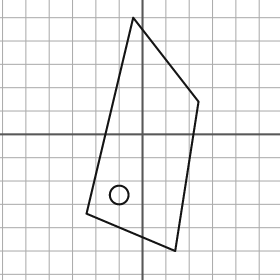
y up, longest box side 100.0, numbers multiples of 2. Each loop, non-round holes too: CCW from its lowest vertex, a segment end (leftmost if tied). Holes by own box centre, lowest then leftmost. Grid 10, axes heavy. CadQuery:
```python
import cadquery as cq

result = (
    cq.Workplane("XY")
    .moveTo(14.0, -50.0)
    .lineTo(24.0, 14.0)
    .lineTo(-4.0, 50.0)
    .lineTo(-24.0, -34.0)
    .close()
    .moveTo(-10.0, -26.0)
    .circle(4.0)
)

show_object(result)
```